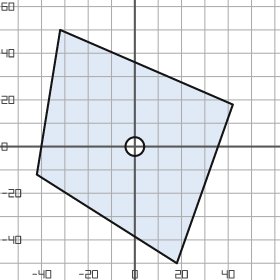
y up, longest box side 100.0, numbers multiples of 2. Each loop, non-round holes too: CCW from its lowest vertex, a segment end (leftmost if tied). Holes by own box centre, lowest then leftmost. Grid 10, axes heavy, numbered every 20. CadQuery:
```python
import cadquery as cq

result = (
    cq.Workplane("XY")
    .moveTo(18.0, -50.0)
    .lineTo(42.0, 18.0)
    .lineTo(-32.0, 50.0)
    .lineTo(-42.0, -12.0)
    .close()
    .moveTo(0.0, 0.0)
    .circle(4.0)
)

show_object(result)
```